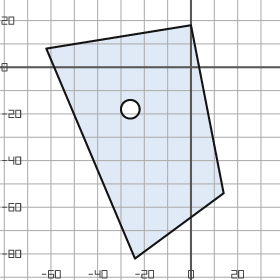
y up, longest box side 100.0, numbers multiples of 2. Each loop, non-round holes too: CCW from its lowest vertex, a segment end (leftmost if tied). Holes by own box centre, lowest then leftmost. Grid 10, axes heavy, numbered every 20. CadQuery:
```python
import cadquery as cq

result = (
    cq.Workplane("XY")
    .moveTo(-24.0, -82.0)
    .lineTo(14.0, -54.0)
    .lineTo(0.0, 18.0)
    .lineTo(-62.0, 8.0)
    .close()
    .moveTo(-26.0, -18.0)
    .circle(4.0)
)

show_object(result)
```